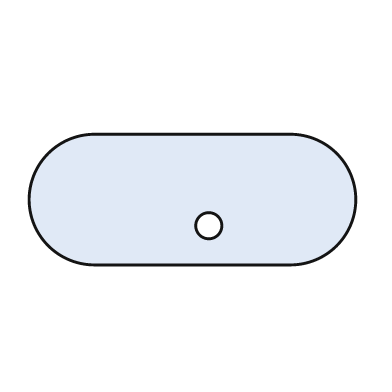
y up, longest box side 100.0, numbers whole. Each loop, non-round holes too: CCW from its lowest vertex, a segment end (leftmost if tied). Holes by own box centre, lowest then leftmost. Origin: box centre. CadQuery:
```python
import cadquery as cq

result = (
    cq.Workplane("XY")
    .moveTo(-30.0, -20.0)
    .lineTo(30.0, -20.0)
    .threePointArc((50.0, 0.0), (30.0, 20.0))
    .lineTo(-30.0, 20.0)
    .threePointArc((-50.0, 0.0), (-30.0, -20.0))
    .close()
    .moveTo(5.0, -8.0)
    .circle(4.0)
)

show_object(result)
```